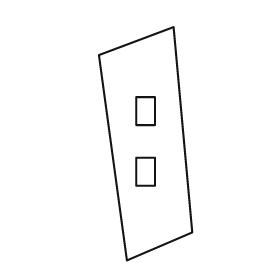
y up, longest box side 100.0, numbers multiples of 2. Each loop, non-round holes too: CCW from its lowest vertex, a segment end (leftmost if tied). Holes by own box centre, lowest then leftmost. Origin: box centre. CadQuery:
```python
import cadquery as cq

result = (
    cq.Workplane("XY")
    .moveTo(-8.0, -50.0)
    .lineTo(20.0, -38.0)
    .lineTo(12.0, 50.0)
    .lineTo(-20.0, 38.0)
    .close()
    .moveTo(-4.0, -18.0)
    .lineTo(4.0, -18.0)
    .lineTo(4.0, -6.0)
    .lineTo(-4.0, -6.0)
    .close()
    .moveTo(-4.0, 8.0)
    .lineTo(4.0, 8.0)
    .lineTo(4.0, 20.0)
    .lineTo(-4.0, 20.0)
    .close()
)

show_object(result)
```